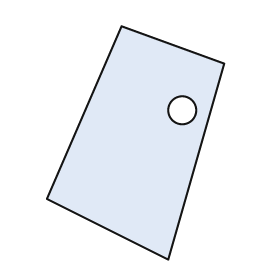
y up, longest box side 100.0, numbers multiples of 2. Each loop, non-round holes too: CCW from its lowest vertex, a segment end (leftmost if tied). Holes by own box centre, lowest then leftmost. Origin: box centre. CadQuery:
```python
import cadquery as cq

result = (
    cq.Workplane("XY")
    .moveTo(14.0, -50.0)
    .lineTo(38.0, 34.0)
    .lineTo(-6.0, 50.0)
    .lineTo(-38.0, -24.0)
    .close()
    .moveTo(20.0, 14.0)
    .circle(6.0)
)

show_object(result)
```